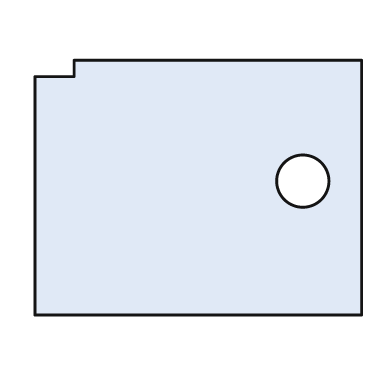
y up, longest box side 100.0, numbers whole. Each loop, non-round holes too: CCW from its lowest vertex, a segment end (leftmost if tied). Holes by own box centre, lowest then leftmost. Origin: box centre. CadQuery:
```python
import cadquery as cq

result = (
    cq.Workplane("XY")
    .moveTo(-50.0, -39.0)
    .lineTo(50.0, -39.0)
    .lineTo(50.0, 39.0)
    .lineTo(-38.0, 39.0)
    .lineTo(-38.0, 34.0)
    .lineTo(-50.0, 34.0)
    .close()
    .moveTo(32.0, 2.0)
    .circle(8.0)
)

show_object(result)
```